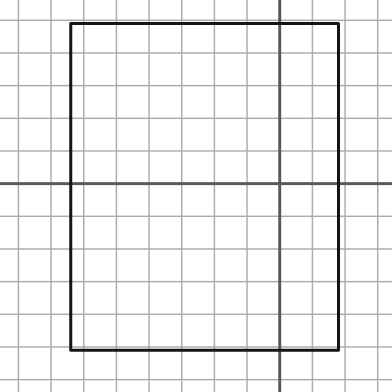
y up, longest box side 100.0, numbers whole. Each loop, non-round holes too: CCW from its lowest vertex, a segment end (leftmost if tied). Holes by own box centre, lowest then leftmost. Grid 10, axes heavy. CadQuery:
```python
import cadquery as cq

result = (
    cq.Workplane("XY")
    .moveTo(-64.0, -51.0)
    .lineTo(18.0, -51.0)
    .lineTo(18.0, 49.0)
    .lineTo(-64.0, 49.0)
    .close()
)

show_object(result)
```